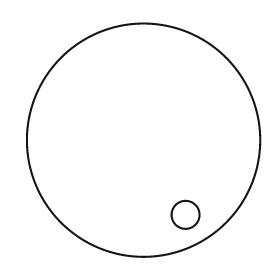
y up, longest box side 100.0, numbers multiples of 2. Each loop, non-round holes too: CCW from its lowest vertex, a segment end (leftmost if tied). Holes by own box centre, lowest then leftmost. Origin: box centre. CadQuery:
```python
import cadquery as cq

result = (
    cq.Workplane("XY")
    .moveTo(0.0, 0.0)
    .circle(50.0)
    .moveTo(18.0, -32.0)
    .circle(6.0)
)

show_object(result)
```